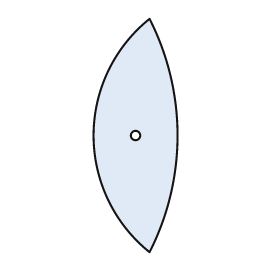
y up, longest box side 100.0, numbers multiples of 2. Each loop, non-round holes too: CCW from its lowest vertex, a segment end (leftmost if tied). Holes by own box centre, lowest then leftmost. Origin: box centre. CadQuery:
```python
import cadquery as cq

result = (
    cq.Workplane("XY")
    .moveTo(6.0, -50.0)
    .threePointArc((18.0, 0.0), (6.0, 50.0))
    .threePointArc((-18.0, 0.0), (6.0, -50.0))
    .close()
    .moveTo(0.0, 0.0)
    .circle(2.0)
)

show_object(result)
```